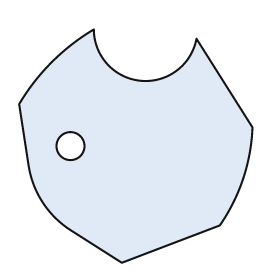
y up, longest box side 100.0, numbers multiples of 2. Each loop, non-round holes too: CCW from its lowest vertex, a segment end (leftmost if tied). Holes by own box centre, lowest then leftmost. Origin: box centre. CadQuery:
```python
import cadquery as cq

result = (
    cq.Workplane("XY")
    .moveTo(-6.0, -50.0)
    .lineTo(36.0, -34.0)
    .threePointArc((46.0, -14.0), (50.0, 8.0))
    .lineTo(26.0, 46.0)
    .threePointArc((2.0, 28.0), (-18.0, 50.0))
    .threePointArc((-36.0, 36.0), (-50.0, 18.0))
    .lineTo(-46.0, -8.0)
    .threePointArc((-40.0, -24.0), (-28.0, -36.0))
    .close()
    .moveTo(-28.0, 0.0)
    .circle(6.0)
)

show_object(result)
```